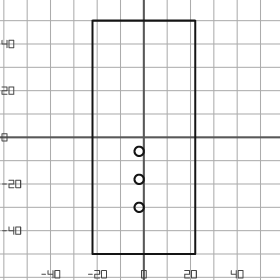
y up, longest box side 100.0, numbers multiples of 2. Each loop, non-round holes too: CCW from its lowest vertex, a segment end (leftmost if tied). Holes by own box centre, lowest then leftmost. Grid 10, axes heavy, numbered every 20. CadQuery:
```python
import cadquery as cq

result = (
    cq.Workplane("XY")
    .moveTo(-22.0, -50.0)
    .lineTo(22.0, -50.0)
    .lineTo(22.0, 50.0)
    .lineTo(-22.0, 50.0)
    .close()
    .moveTo(-2.0, -30.0)
    .circle(2.0)
    .moveTo(-2.0, -18.0)
    .circle(2.0)
    .moveTo(-2.0, -6.0)
    .circle(2.0)
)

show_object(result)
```